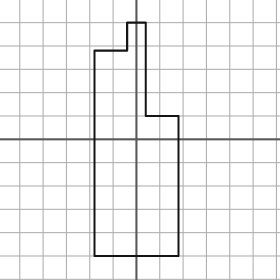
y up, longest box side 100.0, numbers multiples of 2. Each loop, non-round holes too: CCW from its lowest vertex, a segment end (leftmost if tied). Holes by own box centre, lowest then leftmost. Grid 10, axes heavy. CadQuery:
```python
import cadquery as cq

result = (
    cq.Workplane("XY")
    .moveTo(-18.0, -50.0)
    .lineTo(18.0, -50.0)
    .lineTo(18.0, 10.0)
    .lineTo(4.0, 10.0)
    .lineTo(4.0, 50.0)
    .lineTo(-4.0, 50.0)
    .lineTo(-4.0, 38.0)
    .lineTo(-18.0, 38.0)
    .close()
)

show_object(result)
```